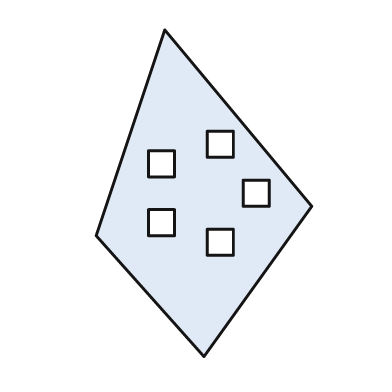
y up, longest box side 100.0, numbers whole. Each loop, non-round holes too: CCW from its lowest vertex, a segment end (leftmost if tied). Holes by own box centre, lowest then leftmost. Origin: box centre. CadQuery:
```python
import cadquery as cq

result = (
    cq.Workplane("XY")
    .moveTo(0.0, -50.0)
    .lineTo(33.0, -4.0)
    .lineTo(-12.0, 50.0)
    .lineTo(-33.0, -13.0)
    .close()
    .moveTo(1.0, -19.0)
    .lineTo(9.0, -19.0)
    .lineTo(9.0, -11.0)
    .lineTo(1.0, -11.0)
    .close()
    .moveTo(-17.0, -13.0)
    .lineTo(-9.0, -13.0)
    .lineTo(-9.0, -5.0)
    .lineTo(-17.0, -5.0)
    .close()
    .moveTo(12.0, -4.0)
    .lineTo(20.0, -4.0)
    .lineTo(20.0, 4.0)
    .lineTo(12.0, 4.0)
    .close()
    .moveTo(-17.0, 5.0)
    .lineTo(-9.0, 5.0)
    .lineTo(-9.0, 13.0)
    .lineTo(-17.0, 13.0)
    .close()
    .moveTo(1.0, 11.0)
    .lineTo(9.0, 11.0)
    .lineTo(9.0, 19.0)
    .lineTo(1.0, 19.0)
    .close()
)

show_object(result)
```